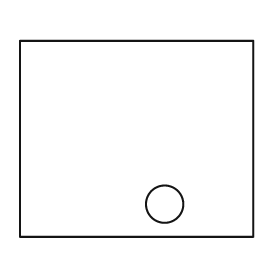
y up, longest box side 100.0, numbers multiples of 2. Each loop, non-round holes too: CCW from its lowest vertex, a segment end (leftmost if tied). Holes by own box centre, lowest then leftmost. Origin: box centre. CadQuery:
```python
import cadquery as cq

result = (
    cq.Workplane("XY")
    .moveTo(-50.0, -42.0)
    .lineTo(50.0, -42.0)
    .lineTo(50.0, 42.0)
    .lineTo(-50.0, 42.0)
    .close()
    .moveTo(12.0, -28.0)
    .circle(8.0)
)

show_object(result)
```